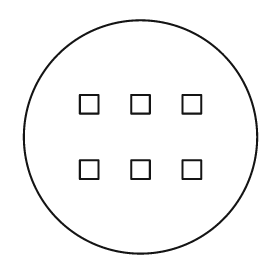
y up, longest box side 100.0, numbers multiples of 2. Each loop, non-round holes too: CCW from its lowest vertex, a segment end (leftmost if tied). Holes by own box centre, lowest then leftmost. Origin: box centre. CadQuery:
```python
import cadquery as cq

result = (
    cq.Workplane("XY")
    .moveTo(0.0, 0.0)
    .circle(50.0)
    .moveTo(-26.0, -18.0)
    .lineTo(-18.0, -18.0)
    .lineTo(-18.0, -10.0)
    .lineTo(-26.0, -10.0)
    .close()
    .moveTo(-4.0, -18.0)
    .lineTo(4.0, -18.0)
    .lineTo(4.0, -10.0)
    .lineTo(-4.0, -10.0)
    .close()
    .moveTo(18.0, -18.0)
    .lineTo(26.0, -18.0)
    .lineTo(26.0, -10.0)
    .lineTo(18.0, -10.0)
    .close()
    .moveTo(-26.0, 10.0)
    .lineTo(-18.0, 10.0)
    .lineTo(-18.0, 18.0)
    .lineTo(-26.0, 18.0)
    .close()
    .moveTo(-4.0, 10.0)
    .lineTo(4.0, 10.0)
    .lineTo(4.0, 18.0)
    .lineTo(-4.0, 18.0)
    .close()
    .moveTo(18.0, 10.0)
    .lineTo(26.0, 10.0)
    .lineTo(26.0, 18.0)
    .lineTo(18.0, 18.0)
    .close()
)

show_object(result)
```